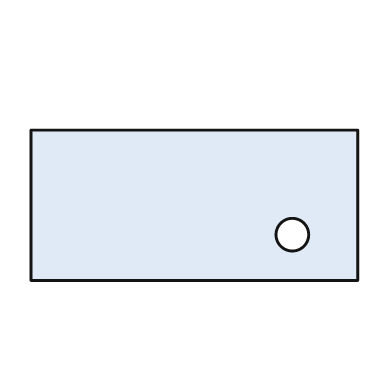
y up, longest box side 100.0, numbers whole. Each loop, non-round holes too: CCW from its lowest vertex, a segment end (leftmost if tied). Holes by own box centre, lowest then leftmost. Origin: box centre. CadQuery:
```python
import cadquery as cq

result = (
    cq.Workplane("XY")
    .moveTo(-50.0, -23.0)
    .lineTo(50.0, -23.0)
    .lineTo(50.0, 23.0)
    .lineTo(-50.0, 23.0)
    .close()
    .moveTo(30.0, -9.0)
    .circle(5.0)
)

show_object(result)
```